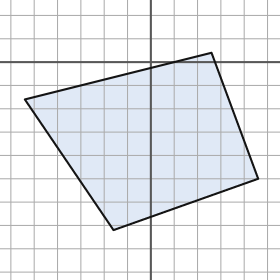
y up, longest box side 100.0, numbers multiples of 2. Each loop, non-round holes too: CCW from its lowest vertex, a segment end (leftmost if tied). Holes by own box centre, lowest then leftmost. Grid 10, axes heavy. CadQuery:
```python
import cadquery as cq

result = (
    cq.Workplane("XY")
    .moveTo(-16.0, -72.0)
    .lineTo(46.0, -50.0)
    .lineTo(26.0, 4.0)
    .lineTo(-54.0, -16.0)
    .close()
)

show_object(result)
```